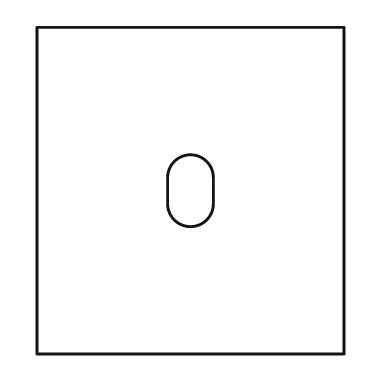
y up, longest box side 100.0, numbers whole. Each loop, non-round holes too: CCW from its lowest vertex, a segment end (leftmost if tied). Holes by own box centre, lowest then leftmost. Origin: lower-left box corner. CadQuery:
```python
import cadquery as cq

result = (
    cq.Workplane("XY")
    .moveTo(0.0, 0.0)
    .lineTo(94.0, 0.0)
    .lineTo(94.0, 100.0)
    .lineTo(0.0, 100.0)
    .close()
    .moveTo(40.0, 46.0)
    .threePointArc((47.0, 39.0), (54.0, 46.0))
    .lineTo(54.0, 54.0)
    .threePointArc((47.0, 61.0), (40.0, 54.0))
    .close()
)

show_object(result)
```